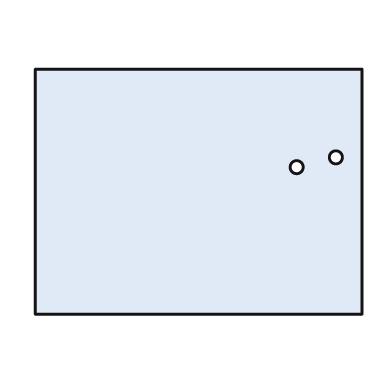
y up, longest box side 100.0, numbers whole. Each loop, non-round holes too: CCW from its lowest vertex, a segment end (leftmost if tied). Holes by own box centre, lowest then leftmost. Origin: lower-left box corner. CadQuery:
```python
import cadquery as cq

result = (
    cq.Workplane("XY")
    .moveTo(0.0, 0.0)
    .lineTo(100.0, 0.0)
    .lineTo(100.0, 75.0)
    .lineTo(0.0, 75.0)
    .close()
    .moveTo(80.0, 45.0)
    .circle(2.0)
    .moveTo(92.0, 48.0)
    .circle(2.0)
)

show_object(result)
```